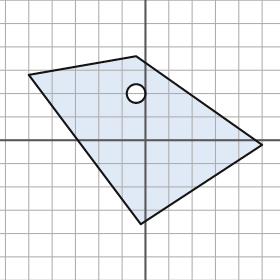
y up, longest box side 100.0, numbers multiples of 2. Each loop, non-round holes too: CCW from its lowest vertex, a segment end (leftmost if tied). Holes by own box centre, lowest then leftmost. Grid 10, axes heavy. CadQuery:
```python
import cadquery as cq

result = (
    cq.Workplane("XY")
    .moveTo(-2.0, -36.0)
    .lineTo(50.0, -2.0)
    .lineTo(-4.0, 36.0)
    .lineTo(-50.0, 28.0)
    .close()
    .moveTo(-4.0, 20.0)
    .circle(4.0)
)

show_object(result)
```